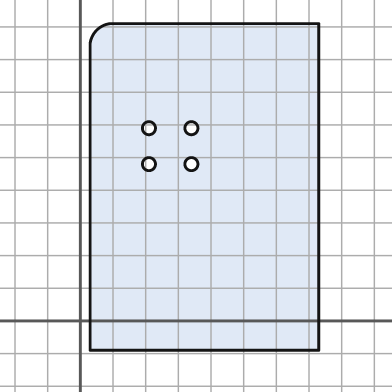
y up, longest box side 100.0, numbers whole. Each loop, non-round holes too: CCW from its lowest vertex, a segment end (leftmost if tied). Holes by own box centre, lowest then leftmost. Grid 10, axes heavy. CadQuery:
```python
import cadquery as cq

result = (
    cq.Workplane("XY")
    .moveTo(3.0, -9.0)
    .lineTo(73.0, -9.0)
    .lineTo(73.0, 91.0)
    .lineTo(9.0, 91.0)
    .threePointArc((5.0, 89.0), (3.0, 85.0))
    .close()
    .moveTo(21.0, 48.0)
    .circle(2.0)
    .moveTo(34.0, 48.0)
    .circle(2.0)
    .moveTo(21.0, 59.0)
    .circle(2.0)
    .moveTo(34.0, 59.0)
    .circle(2.0)
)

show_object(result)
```